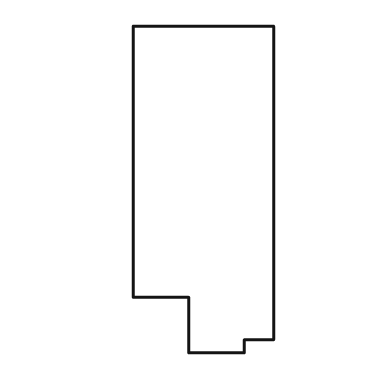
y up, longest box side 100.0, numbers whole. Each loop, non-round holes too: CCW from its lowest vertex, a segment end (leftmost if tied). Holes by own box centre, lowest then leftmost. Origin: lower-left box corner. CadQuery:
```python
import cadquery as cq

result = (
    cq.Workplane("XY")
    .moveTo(17.0, 0.0)
    .lineTo(34.0, 0.0)
    .lineTo(34.0, 4.0)
    .lineTo(43.0, 4.0)
    .lineTo(43.0, 100.0)
    .lineTo(0.0, 100.0)
    .lineTo(0.0, 17.0)
    .lineTo(17.0, 17.0)
    .close()
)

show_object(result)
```